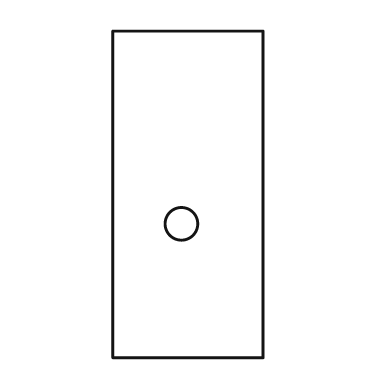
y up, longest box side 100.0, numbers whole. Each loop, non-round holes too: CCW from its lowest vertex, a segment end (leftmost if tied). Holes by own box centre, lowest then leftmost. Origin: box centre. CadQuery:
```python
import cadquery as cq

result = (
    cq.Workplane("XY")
    .moveTo(-23.0, -50.0)
    .lineTo(23.0, -50.0)
    .lineTo(23.0, 50.0)
    .lineTo(-23.0, 50.0)
    .close()
    .moveTo(-2.0, -9.0)
    .circle(5.0)
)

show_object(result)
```